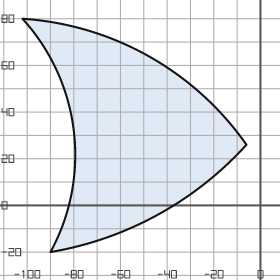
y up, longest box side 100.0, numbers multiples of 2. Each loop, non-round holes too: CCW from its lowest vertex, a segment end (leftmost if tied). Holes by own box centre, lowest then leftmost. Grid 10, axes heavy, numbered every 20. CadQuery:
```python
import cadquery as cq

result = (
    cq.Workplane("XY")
    .moveTo(-90.0, -20.0)
    .threePointArc((-44.0, -4.0), (-6.0, 26.0))
    .threePointArc((-48.0, 64.0), (-102.0, 80.0))
    .threePointArc((-80.0, 32.0), (-90.0, -20.0))
    .close()
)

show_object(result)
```